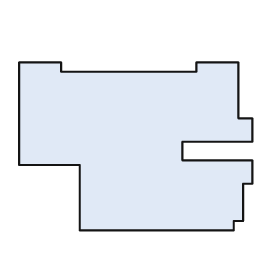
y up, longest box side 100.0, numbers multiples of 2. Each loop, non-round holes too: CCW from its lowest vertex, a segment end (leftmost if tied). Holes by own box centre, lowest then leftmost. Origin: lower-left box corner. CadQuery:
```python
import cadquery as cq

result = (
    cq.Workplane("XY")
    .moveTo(26.0, 0.0)
    .lineTo(92.0, 0.0)
    .lineTo(92.0, 4.0)
    .lineTo(96.0, 4.0)
    .lineTo(96.0, 20.0)
    .lineTo(100.0, 20.0)
    .lineTo(100.0, 30.0)
    .lineTo(70.0, 30.0)
    .lineTo(70.0, 38.0)
    .lineTo(100.0, 38.0)
    .lineTo(100.0, 48.0)
    .lineTo(94.0, 48.0)
    .lineTo(94.0, 72.0)
    .lineTo(76.0, 72.0)
    .lineTo(76.0, 68.0)
    .lineTo(18.0, 68.0)
    .lineTo(18.0, 72.0)
    .lineTo(0.0, 72.0)
    .lineTo(0.0, 28.0)
    .lineTo(26.0, 28.0)
    .close()
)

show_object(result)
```